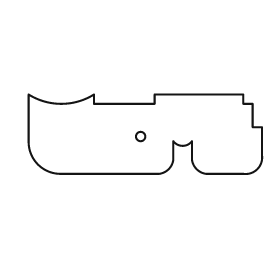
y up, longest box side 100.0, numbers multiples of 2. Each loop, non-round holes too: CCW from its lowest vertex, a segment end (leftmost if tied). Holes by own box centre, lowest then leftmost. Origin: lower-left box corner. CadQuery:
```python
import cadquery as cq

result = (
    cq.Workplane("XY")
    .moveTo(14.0, 0.0)
    .lineTo(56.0, 0.0)
    .threePointArc((60.0, 2.0), (62.0, 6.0))
    .lineTo(62.0, 14.0)
    .threePointArc((66.0, 12.0), (70.0, 14.0))
    .lineTo(70.0, 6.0)
    .threePointArc((72.0, 2.0), (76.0, 0.0))
    .lineTo(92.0, 0.0)
    .threePointArc((98.0, 2.0), (100.0, 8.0))
    .lineTo(100.0, 20.0)
    .lineTo(96.0, 20.0)
    .lineTo(96.0, 30.0)
    .lineTo(92.0, 30.0)
    .lineTo(92.0, 34.0)
    .lineTo(54.0, 34.0)
    .lineTo(54.0, 30.0)
    .lineTo(28.0, 30.0)
    .lineTo(28.0, 34.0)
    .threePointArc((14.0, 30.0), (0.0, 34.0))
    .lineTo(0.0, 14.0)
    .threePointArc((4.0, 4.0), (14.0, 0.0))
    .close()
    .moveTo(48.0, 16.0)
    .circle(2.0)
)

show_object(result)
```